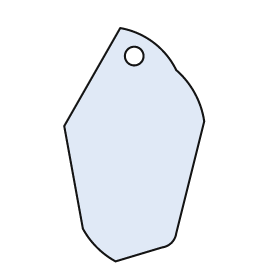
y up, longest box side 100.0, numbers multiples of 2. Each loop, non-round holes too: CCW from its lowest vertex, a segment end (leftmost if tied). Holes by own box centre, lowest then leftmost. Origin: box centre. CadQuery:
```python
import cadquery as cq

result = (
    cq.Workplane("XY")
    .moveTo(-8.0, -50.0)
    .lineTo(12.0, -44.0)
    .threePointArc((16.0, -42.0), (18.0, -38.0))
    .lineTo(30.0, 10.0)
    .threePointArc((26.0, 22.0), (18.0, 32.0))
    .threePointArc((8.0, 44.0), (-6.0, 50.0))
    .lineTo(-30.0, 8.0)
    .lineTo(-22.0, -36.0)
    .threePointArc((-16.0, -44.0), (-8.0, -50.0))
    .close()
    .moveTo(0.0, 38.0)
    .circle(4.0)
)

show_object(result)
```